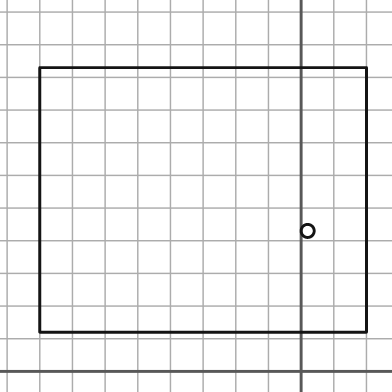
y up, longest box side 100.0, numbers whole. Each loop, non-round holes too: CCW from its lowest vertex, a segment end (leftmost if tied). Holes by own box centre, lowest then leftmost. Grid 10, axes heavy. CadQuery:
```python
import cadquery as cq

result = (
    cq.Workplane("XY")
    .moveTo(-80.0, 12.0)
    .lineTo(20.0, 12.0)
    .lineTo(20.0, 93.0)
    .lineTo(-80.0, 93.0)
    .close()
    .moveTo(2.0, 43.0)
    .circle(2.0)
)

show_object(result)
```